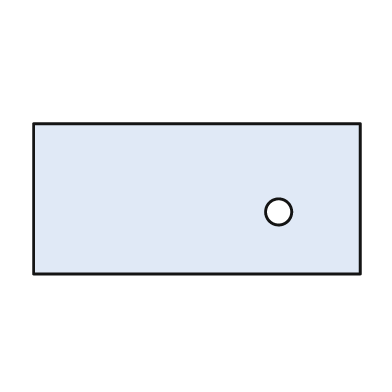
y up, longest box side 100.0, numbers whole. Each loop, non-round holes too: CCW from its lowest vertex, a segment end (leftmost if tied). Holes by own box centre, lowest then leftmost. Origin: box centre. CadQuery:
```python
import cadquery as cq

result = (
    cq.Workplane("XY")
    .moveTo(-50.0, -23.0)
    .lineTo(50.0, -23.0)
    .lineTo(50.0, 23.0)
    .lineTo(-50.0, 23.0)
    .close()
    .moveTo(25.0, -4.0)
    .circle(4.0)
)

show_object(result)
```